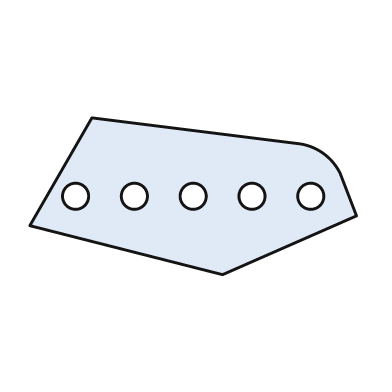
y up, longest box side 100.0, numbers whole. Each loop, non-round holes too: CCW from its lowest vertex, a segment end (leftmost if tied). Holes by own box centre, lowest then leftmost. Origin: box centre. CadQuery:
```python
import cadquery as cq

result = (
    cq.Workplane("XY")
    .moveTo(9.0, -24.0)
    .lineTo(50.0, -6.0)
    .lineTo(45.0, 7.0)
    .threePointArc((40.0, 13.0), (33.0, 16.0))
    .lineTo(-31.0, 24.0)
    .lineTo(-50.0, -9.0)
    .close()
    .moveTo(-36.0, 0.0)
    .circle(4.0)
    .moveTo(-18.0, 0.0)
    .circle(4.0)
    .moveTo(0.0, 0.0)
    .circle(4.0)
    .moveTo(18.0, 0.0)
    .circle(4.0)
    .moveTo(36.0, 0.0)
    .circle(4.0)
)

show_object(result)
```